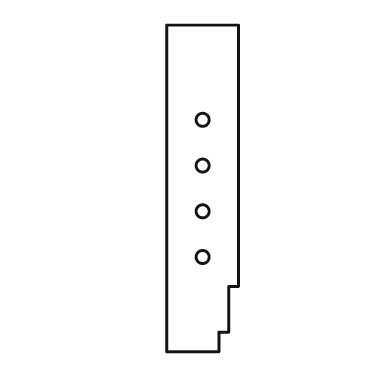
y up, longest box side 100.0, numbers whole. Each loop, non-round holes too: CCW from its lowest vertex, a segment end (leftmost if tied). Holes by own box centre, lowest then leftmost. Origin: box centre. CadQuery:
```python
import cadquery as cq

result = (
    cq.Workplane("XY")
    .moveTo(-11.0, -50.0)
    .lineTo(5.0, -50.0)
    .lineTo(5.0, -44.0)
    .lineTo(8.0, -44.0)
    .lineTo(8.0, -30.0)
    .lineTo(11.0, -30.0)
    .lineTo(11.0, 50.0)
    .lineTo(-11.0, 50.0)
    .close()
    .moveTo(0.0, -21.0)
    .circle(2.0)
    .moveTo(0.0, -7.0)
    .circle(2.0)
    .moveTo(0.0, 7.0)
    .circle(2.0)
    .moveTo(0.0, 21.0)
    .circle(2.0)
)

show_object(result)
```